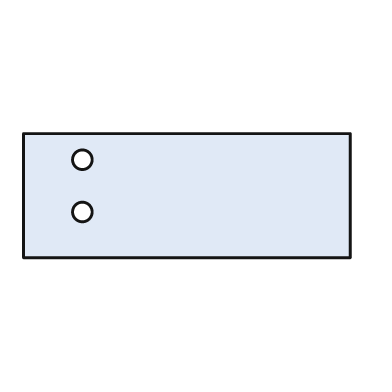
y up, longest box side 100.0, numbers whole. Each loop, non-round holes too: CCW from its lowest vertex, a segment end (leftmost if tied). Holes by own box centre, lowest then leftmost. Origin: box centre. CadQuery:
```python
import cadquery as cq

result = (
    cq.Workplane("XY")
    .moveTo(-50.0, -19.0)
    .lineTo(50.0, -19.0)
    .lineTo(50.0, 19.0)
    .lineTo(-50.0, 19.0)
    .close()
    .moveTo(-32.0, -5.0)
    .circle(3.0)
    .moveTo(-32.0, 11.0)
    .circle(3.0)
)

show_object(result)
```